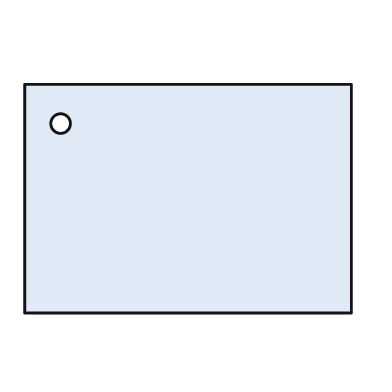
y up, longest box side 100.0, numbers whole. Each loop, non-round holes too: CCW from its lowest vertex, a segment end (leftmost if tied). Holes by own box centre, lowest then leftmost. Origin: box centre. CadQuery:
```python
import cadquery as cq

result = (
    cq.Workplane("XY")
    .moveTo(-50.0, -35.0)
    .lineTo(50.0, -35.0)
    .lineTo(50.0, 35.0)
    .lineTo(-50.0, 35.0)
    .close()
    .moveTo(-39.0, 23.0)
    .circle(3.0)
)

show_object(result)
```